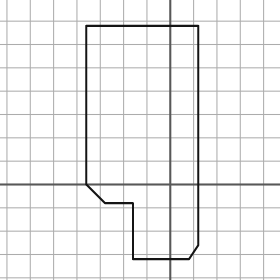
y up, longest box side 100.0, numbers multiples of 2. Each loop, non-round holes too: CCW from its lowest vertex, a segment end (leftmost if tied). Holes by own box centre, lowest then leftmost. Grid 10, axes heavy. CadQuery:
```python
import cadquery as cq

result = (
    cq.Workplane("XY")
    .moveTo(-16.0, -32.0)
    .lineTo(8.0, -32.0)
    .lineTo(12.0, -26.0)
    .lineTo(12.0, 68.0)
    .lineTo(-36.0, 68.0)
    .lineTo(-36.0, 0.0)
    .lineTo(-28.0, -8.0)
    .lineTo(-16.0, -8.0)
    .close()
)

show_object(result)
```